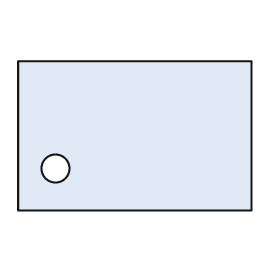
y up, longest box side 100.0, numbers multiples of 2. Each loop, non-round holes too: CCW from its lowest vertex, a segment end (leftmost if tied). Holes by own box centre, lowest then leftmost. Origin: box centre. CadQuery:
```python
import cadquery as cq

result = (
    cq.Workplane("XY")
    .moveTo(-50.0, -32.0)
    .lineTo(50.0, -32.0)
    .lineTo(50.0, 32.0)
    .lineTo(-50.0, 32.0)
    .close()
    .moveTo(-34.0, -14.0)
    .circle(6.0)
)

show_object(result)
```